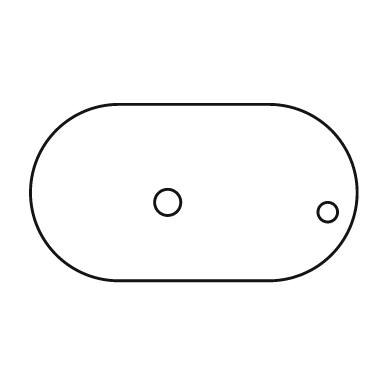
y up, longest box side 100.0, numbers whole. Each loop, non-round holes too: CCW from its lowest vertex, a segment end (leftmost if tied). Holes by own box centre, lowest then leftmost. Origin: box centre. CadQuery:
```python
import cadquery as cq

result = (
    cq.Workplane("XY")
    .moveTo(-23.0, -27.0)
    .lineTo(23.0, -27.0)
    .threePointArc((50.0, 0.0), (23.0, 27.0))
    .lineTo(-23.0, 27.0)
    .threePointArc((-50.0, 0.0), (-23.0, -27.0))
    .close()
    .moveTo(41.0, -6.0)
    .circle(3.0)
    .moveTo(-8.0, -3.0)
    .circle(4.0)
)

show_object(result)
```